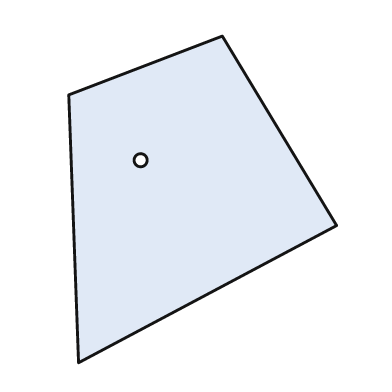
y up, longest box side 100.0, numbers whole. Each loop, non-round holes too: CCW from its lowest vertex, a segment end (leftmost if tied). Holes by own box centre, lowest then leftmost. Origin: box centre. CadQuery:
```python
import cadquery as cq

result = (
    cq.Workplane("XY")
    .moveTo(-38.0, -50.0)
    .lineTo(41.0, -8.0)
    .lineTo(6.0, 50.0)
    .lineTo(-41.0, 32.0)
    .close()
    .moveTo(-19.0, 12.0)
    .circle(2.0)
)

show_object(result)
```